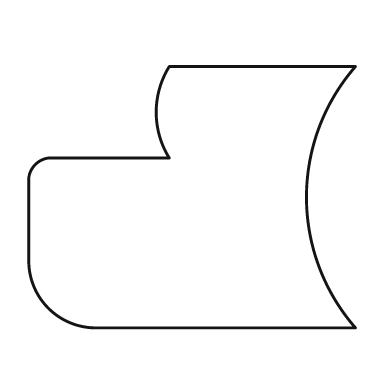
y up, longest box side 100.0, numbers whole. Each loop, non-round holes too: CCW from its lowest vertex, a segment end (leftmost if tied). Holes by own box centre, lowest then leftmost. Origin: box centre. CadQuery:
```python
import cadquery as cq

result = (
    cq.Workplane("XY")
    .moveTo(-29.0, -40.0)
    .lineTo(50.0, -40.0)
    .threePointArc((35.0, 0.0), (50.0, 40.0))
    .lineTo(-7.0, 40.0)
    .threePointArc((-11.0, 26.0), (-7.0, 12.0))
    .lineTo(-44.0, 12.0)
    .threePointArc((-48.0, 10.0), (-50.0, 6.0))
    .lineTo(-50.0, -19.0)
    .threePointArc((-44.0, -34.0), (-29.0, -40.0))
    .close()
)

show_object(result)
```